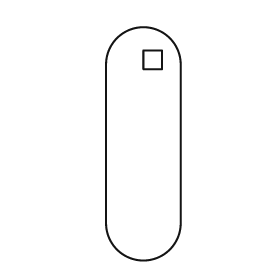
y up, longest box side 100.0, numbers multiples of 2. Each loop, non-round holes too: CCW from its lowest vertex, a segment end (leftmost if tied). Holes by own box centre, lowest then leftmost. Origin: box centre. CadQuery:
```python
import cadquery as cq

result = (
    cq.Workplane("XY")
    .moveTo(-16.0, -34.0)
    .threePointArc((0.0, -50.0), (16.0, -34.0))
    .lineTo(16.0, 34.0)
    .threePointArc((0.0, 50.0), (-16.0, 34.0))
    .close()
    .moveTo(0.0, 32.0)
    .lineTo(8.0, 32.0)
    .lineTo(8.0, 40.0)
    .lineTo(0.0, 40.0)
    .close()
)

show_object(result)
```